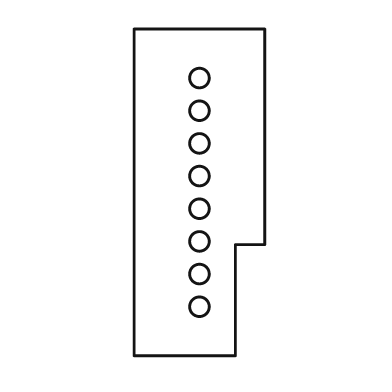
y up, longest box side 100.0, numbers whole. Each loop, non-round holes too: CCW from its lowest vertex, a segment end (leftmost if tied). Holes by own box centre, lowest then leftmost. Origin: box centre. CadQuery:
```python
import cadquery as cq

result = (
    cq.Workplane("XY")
    .moveTo(-20.0, -50.0)
    .lineTo(11.0, -50.0)
    .lineTo(11.0, -16.0)
    .lineTo(20.0, -16.0)
    .lineTo(20.0, 50.0)
    .lineTo(-20.0, 50.0)
    .close()
    .moveTo(0.0, -35.0)
    .circle(3.0)
    .moveTo(0.0, -25.0)
    .circle(3.0)
    .moveTo(0.0, -15.0)
    .circle(3.0)
    .moveTo(0.0, -5.0)
    .circle(3.0)
    .moveTo(0.0, 5.0)
    .circle(3.0)
    .moveTo(0.0, 15.0)
    .circle(3.0)
    .moveTo(0.0, 25.0)
    .circle(3.0)
    .moveTo(0.0, 35.0)
    .circle(3.0)
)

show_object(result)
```